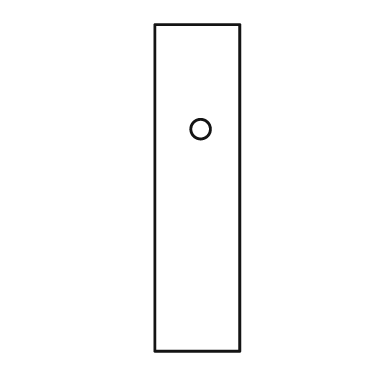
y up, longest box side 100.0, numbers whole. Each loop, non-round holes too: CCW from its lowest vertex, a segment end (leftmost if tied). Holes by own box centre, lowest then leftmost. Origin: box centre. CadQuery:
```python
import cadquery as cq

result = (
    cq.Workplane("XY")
    .moveTo(-13.0, -50.0)
    .lineTo(13.0, -50.0)
    .lineTo(13.0, 50.0)
    .lineTo(-13.0, 50.0)
    .close()
    .moveTo(1.0, 18.0)
    .circle(3.0)
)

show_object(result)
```